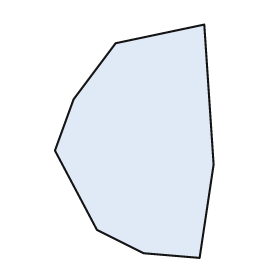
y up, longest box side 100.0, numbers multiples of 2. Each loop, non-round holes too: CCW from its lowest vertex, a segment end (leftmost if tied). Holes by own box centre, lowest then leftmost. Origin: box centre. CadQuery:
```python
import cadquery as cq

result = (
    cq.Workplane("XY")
    .moveTo(28.0, -50.0)
    .lineTo(34.0, -10.0)
    .lineTo(30.0, 50.0)
    .lineTo(-8.0, 42.0)
    .lineTo(-26.0, 18.0)
    .lineTo(-34.0, -4.0)
    .lineTo(-16.0, -38.0)
    .lineTo(4.0, -48.0)
    .close()
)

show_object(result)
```